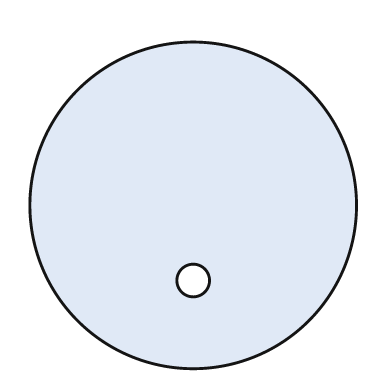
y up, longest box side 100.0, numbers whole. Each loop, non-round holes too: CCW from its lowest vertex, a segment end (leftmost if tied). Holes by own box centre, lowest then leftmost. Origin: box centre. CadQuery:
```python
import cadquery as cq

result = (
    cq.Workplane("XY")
    .moveTo(0.0, 0.0)
    .circle(50.0)
    .moveTo(0.0, -23.0)
    .circle(5.0)
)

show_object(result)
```